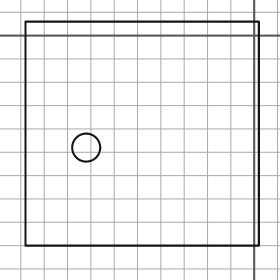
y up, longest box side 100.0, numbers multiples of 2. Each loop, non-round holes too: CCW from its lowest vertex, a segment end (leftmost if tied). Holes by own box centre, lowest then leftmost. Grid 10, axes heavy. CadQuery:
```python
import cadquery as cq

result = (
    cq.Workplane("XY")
    .moveTo(-98.0, -90.0)
    .lineTo(2.0, -90.0)
    .lineTo(2.0, 6.0)
    .lineTo(-98.0, 6.0)
    .close()
    .moveTo(-72.0, -48.0)
    .circle(6.0)
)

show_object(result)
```